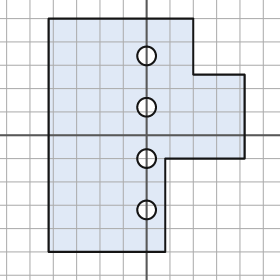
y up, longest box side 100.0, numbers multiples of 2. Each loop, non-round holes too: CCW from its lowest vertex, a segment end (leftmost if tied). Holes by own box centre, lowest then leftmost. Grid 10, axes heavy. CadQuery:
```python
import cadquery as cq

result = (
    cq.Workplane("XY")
    .moveTo(-42.0, -50.0)
    .lineTo(8.0, -50.0)
    .lineTo(8.0, -10.0)
    .lineTo(42.0, -10.0)
    .lineTo(42.0, 26.0)
    .lineTo(20.0, 26.0)
    .lineTo(20.0, 50.0)
    .lineTo(-42.0, 50.0)
    .close()
    .moveTo(0.0, -32.0)
    .circle(4.0)
    .moveTo(0.0, -10.0)
    .circle(4.0)
    .moveTo(0.0, 12.0)
    .circle(4.0)
    .moveTo(0.0, 34.0)
    .circle(4.0)
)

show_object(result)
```